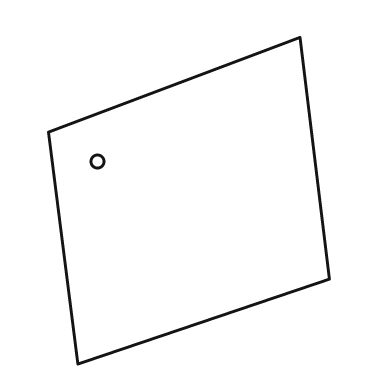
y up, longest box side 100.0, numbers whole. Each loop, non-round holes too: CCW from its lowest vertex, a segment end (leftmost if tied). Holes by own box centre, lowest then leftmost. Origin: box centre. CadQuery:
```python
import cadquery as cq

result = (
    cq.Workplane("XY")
    .moveTo(-34.0, -50.0)
    .lineTo(43.0, -24.0)
    .lineTo(34.0, 50.0)
    .lineTo(-43.0, 21.0)
    .close()
    .moveTo(-28.0, 12.0)
    .circle(2.0)
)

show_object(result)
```